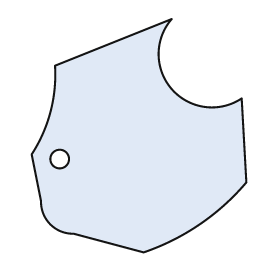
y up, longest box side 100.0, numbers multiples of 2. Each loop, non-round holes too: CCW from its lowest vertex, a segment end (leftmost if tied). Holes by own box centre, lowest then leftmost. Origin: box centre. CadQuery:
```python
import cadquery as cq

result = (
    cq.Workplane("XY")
    .moveTo(2.0, -50.0)
    .threePointArc((26.0, -38.0), (46.0, -20.0))
    .lineTo(44.0, 16.0)
    .threePointArc((14.0, 20.0), (14.0, 50.0))
    .lineTo(-36.0, 30.0)
    .threePointArc((-38.0, 10.0), (-46.0, -8.0))
    .lineTo(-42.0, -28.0)
    .threePointArc((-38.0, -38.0), (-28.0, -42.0))
    .close()
    .moveTo(-34.0, -10.0)
    .circle(4.0)
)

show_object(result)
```